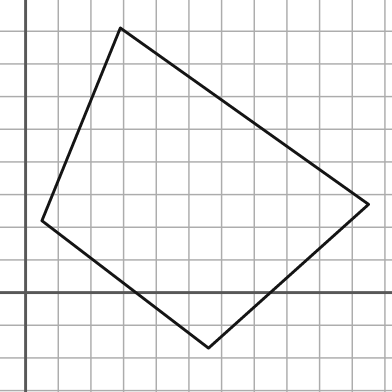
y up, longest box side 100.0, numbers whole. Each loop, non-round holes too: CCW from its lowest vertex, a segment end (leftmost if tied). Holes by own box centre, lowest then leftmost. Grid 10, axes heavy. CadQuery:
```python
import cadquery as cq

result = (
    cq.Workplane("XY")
    .moveTo(56.0, -17.0)
    .lineTo(105.0, 27.0)
    .lineTo(29.0, 81.0)
    .lineTo(5.0, 22.0)
    .close()
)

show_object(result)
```